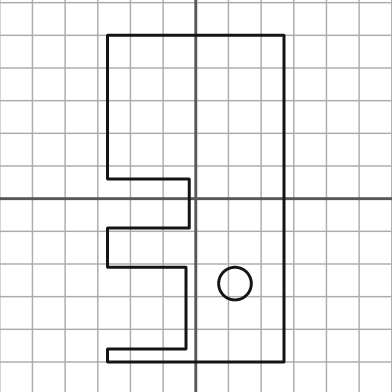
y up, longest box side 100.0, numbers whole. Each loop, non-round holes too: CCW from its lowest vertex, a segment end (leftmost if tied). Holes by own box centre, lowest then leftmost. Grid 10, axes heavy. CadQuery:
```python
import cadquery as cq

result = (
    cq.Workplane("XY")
    .moveTo(-27.0, -50.0)
    .lineTo(27.0, -50.0)
    .lineTo(27.0, 50.0)
    .lineTo(-27.0, 50.0)
    .lineTo(-27.0, 6.0)
    .lineTo(-2.0, 6.0)
    .lineTo(-2.0, -9.0)
    .lineTo(-27.0, -9.0)
    .lineTo(-27.0, -21.0)
    .lineTo(-3.0, -21.0)
    .lineTo(-3.0, -46.0)
    .lineTo(-27.0, -46.0)
    .close()
    .moveTo(12.0, -26.0)
    .circle(5.0)
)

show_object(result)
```